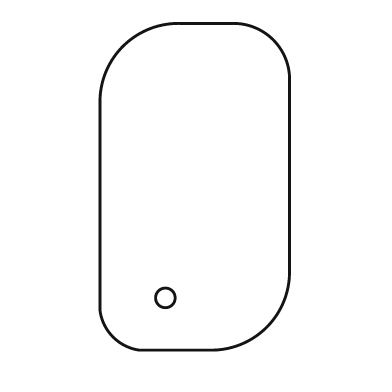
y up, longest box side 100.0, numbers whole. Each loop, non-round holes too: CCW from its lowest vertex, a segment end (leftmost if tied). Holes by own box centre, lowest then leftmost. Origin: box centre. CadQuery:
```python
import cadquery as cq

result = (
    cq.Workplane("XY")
    .moveTo(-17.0, -50.0)
    .lineTo(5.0, -50.0)
    .threePointArc((22.0, -43.0), (29.0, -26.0))
    .lineTo(29.0, 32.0)
    .threePointArc((24.0, 45.0), (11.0, 50.0))
    .lineTo(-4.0, 50.0)
    .threePointArc((-22.0, 43.0), (-29.0, 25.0))
    .lineTo(-29.0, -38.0)
    .threePointArc((-25.0, -46.0), (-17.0, -50.0))
    .close()
    .moveTo(-9.0, -34.0)
    .circle(3.0)
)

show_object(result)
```